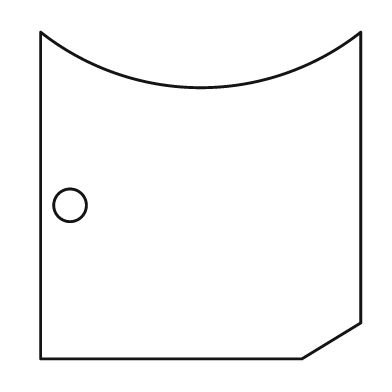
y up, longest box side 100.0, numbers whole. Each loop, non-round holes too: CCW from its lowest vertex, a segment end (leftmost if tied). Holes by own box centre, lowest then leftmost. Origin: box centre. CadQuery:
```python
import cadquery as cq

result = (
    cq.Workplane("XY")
    .moveTo(-49.0, -50.0)
    .lineTo(31.0, -50.0)
    .lineTo(49.0, -39.0)
    .lineTo(49.0, 50.0)
    .threePointArc((0.0, 33.0), (-49.0, 50.0))
    .close()
    .moveTo(-40.0, -3.0)
    .circle(5.0)
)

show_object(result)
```